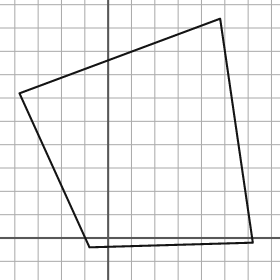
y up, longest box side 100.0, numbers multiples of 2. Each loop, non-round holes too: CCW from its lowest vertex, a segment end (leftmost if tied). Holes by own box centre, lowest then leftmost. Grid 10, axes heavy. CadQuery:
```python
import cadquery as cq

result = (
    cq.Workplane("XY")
    .moveTo(-8.0, -4.0)
    .lineTo(62.0, -2.0)
    .lineTo(48.0, 94.0)
    .lineTo(-38.0, 62.0)
    .close()
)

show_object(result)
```